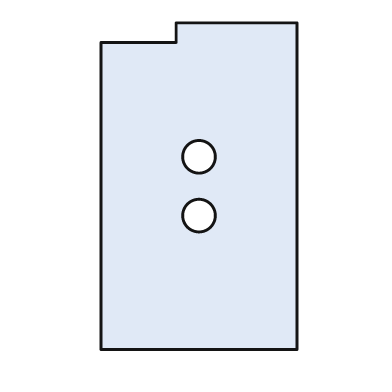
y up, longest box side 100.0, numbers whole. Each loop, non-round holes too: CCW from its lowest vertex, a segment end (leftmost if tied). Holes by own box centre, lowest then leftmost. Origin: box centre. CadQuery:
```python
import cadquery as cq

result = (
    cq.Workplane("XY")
    .moveTo(-30.0, -50.0)
    .lineTo(30.0, -50.0)
    .lineTo(30.0, 50.0)
    .lineTo(-7.0, 50.0)
    .lineTo(-7.0, 44.0)
    .lineTo(-30.0, 44.0)
    .close()
    .moveTo(0.0, -9.0)
    .circle(5.0)
    .moveTo(0.0, 9.0)
    .circle(5.0)
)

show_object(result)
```